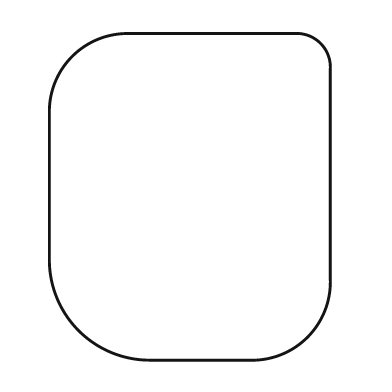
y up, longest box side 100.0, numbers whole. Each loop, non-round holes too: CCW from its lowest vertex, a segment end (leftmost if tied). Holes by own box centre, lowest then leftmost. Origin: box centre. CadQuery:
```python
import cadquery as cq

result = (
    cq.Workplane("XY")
    .moveTo(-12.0, -50.0)
    .lineTo(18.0, -50.0)
    .threePointArc((36.0, -43.0), (43.0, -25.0))
    .lineTo(43.0, 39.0)
    .threePointArc((40.0, 47.0), (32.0, 50.0))
    .lineTo(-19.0, 50.0)
    .threePointArc((-36.0, 43.0), (-43.0, 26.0))
    .lineTo(-43.0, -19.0)
    .threePointArc((-34.0, -41.0), (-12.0, -50.0))
    .close()
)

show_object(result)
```